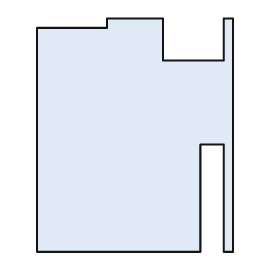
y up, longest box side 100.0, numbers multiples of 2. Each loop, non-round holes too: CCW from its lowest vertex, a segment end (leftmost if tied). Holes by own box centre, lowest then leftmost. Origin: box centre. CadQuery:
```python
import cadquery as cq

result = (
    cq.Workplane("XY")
    .moveTo(-42.0, -50.0)
    .lineTo(28.0, -50.0)
    .lineTo(28.0, -4.0)
    .lineTo(38.0, -4.0)
    .lineTo(38.0, -50.0)
    .lineTo(42.0, -50.0)
    .lineTo(42.0, 50.0)
    .lineTo(38.0, 50.0)
    .lineTo(38.0, 32.0)
    .lineTo(12.0, 32.0)
    .lineTo(12.0, 50.0)
    .lineTo(-12.0, 50.0)
    .lineTo(-12.0, 46.0)
    .lineTo(-42.0, 46.0)
    .close()
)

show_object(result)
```